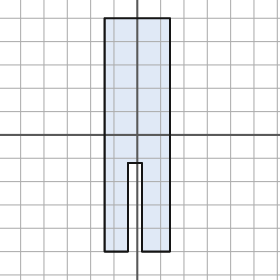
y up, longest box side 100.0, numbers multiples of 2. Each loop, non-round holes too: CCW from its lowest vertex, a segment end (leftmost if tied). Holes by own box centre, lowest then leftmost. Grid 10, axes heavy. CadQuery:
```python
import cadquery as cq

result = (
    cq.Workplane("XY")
    .moveTo(-14.0, -50.0)
    .lineTo(-4.0, -50.0)
    .lineTo(-4.0, -12.0)
    .lineTo(2.0, -12.0)
    .lineTo(2.0, -50.0)
    .lineTo(14.0, -50.0)
    .lineTo(14.0, 50.0)
    .lineTo(-14.0, 50.0)
    .close()
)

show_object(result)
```